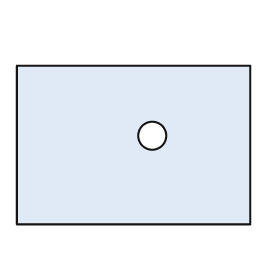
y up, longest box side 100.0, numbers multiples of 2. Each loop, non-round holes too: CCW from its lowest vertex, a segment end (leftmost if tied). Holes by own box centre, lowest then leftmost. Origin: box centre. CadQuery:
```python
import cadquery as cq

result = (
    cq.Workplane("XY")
    .moveTo(-50.0, -34.0)
    .lineTo(50.0, -34.0)
    .lineTo(50.0, 34.0)
    .lineTo(-50.0, 34.0)
    .close()
    .moveTo(8.0, 4.0)
    .circle(6.0)
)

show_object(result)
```